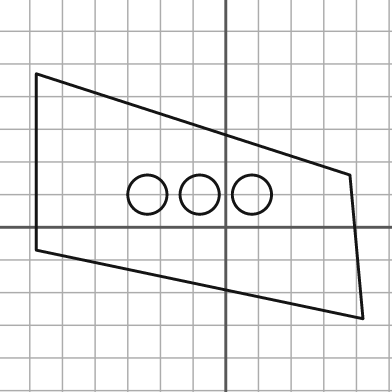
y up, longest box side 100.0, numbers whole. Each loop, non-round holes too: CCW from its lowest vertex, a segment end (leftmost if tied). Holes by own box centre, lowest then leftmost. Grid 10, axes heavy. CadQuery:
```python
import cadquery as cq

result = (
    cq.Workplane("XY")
    .moveTo(42.0, -28.0)
    .lineTo(38.0, 16.0)
    .lineTo(-58.0, 47.0)
    .lineTo(-58.0, -7.0)
    .close()
    .moveTo(-24.0, 10.0)
    .circle(6.0)
    .moveTo(-8.0, 10.0)
    .circle(6.0)
    .moveTo(8.0, 10.0)
    .circle(6.0)
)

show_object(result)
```